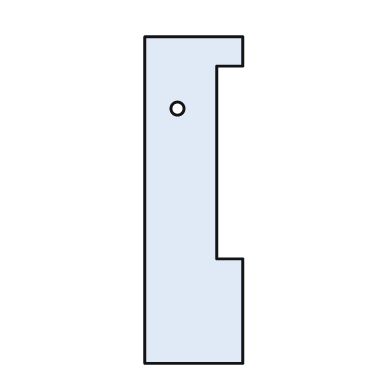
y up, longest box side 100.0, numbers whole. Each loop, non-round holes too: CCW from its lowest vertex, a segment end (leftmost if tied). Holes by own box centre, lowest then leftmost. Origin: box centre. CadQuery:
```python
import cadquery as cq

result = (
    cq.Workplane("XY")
    .moveTo(-15.0, -50.0)
    .lineTo(15.0, -50.0)
    .lineTo(15.0, -18.0)
    .lineTo(7.0, -18.0)
    .lineTo(7.0, 41.0)
    .lineTo(15.0, 41.0)
    .lineTo(15.0, 50.0)
    .lineTo(-15.0, 50.0)
    .close()
    .moveTo(-5.0, 28.0)
    .circle(2.0)
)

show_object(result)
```